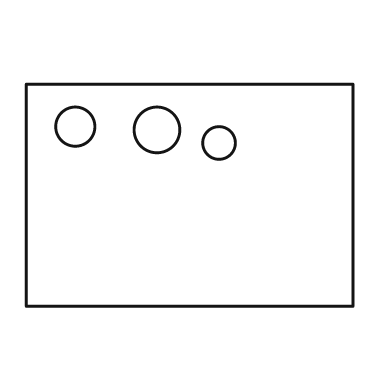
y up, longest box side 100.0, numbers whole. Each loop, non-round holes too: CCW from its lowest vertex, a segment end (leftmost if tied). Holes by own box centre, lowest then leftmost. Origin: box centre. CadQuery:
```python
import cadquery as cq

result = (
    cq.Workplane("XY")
    .moveTo(-50.0, -34.0)
    .lineTo(50.0, -34.0)
    .lineTo(50.0, 34.0)
    .lineTo(-50.0, 34.0)
    .close()
    .moveTo(9.0, 16.0)
    .circle(5.0)
    .moveTo(-10.0, 20.0)
    .circle(7.0)
    .moveTo(-35.0, 21.0)
    .circle(6.0)
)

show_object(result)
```